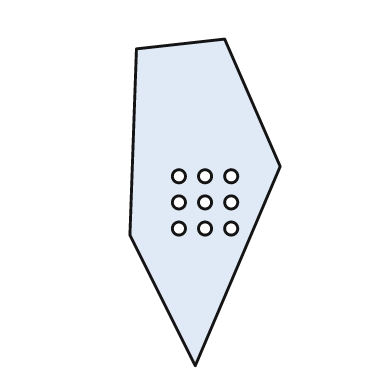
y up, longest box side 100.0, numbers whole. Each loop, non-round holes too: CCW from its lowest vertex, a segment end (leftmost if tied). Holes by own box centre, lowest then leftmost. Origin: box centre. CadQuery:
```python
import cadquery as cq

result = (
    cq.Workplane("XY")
    .moveTo(-3.0, -50.0)
    .lineTo(23.0, 11.0)
    .lineTo(6.0, 50.0)
    .lineTo(-21.0, 47.0)
    .lineTo(-23.0, -10.0)
    .close()
    .moveTo(-8.0, -8.0)
    .circle(2.0)
    .moveTo(0.0, -8.0)
    .circle(2.0)
    .moveTo(8.0, -8.0)
    .circle(2.0)
    .moveTo(-8.0, 0.0)
    .circle(2.0)
    .moveTo(0.0, 0.0)
    .circle(2.0)
    .moveTo(8.0, 0.0)
    .circle(2.0)
    .moveTo(-8.0, 8.0)
    .circle(2.0)
    .moveTo(0.0, 8.0)
    .circle(2.0)
    .moveTo(8.0, 8.0)
    .circle(2.0)
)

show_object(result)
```